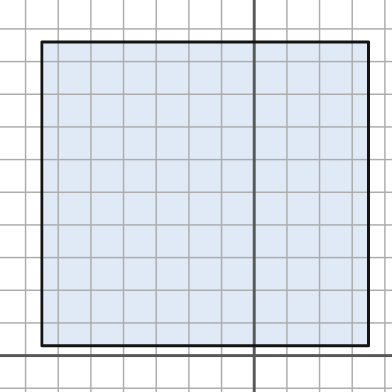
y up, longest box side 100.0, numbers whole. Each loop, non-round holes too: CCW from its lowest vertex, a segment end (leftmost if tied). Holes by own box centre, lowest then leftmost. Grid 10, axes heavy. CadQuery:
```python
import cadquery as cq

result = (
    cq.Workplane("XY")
    .moveTo(-65.0, 3.0)
    .lineTo(35.0, 3.0)
    .lineTo(35.0, 96.0)
    .lineTo(-65.0, 96.0)
    .close()
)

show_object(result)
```